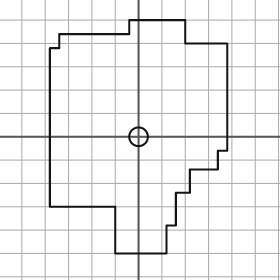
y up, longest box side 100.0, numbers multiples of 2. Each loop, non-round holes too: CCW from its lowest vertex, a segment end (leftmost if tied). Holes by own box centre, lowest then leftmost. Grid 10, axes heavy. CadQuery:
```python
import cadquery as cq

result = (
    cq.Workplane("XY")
    .moveTo(-10.0, -50.0)
    .lineTo(12.0, -50.0)
    .lineTo(12.0, -38.0)
    .lineTo(16.0, -38.0)
    .lineTo(16.0, -24.0)
    .lineTo(22.0, -24.0)
    .lineTo(22.0, -14.0)
    .lineTo(34.0, -14.0)
    .lineTo(34.0, -6.0)
    .lineTo(38.0, -6.0)
    .lineTo(38.0, 40.0)
    .lineTo(20.0, 40.0)
    .lineTo(20.0, 50.0)
    .lineTo(-4.0, 50.0)
    .lineTo(-4.0, 44.0)
    .lineTo(-34.0, 44.0)
    .lineTo(-34.0, 38.0)
    .lineTo(-38.0, 38.0)
    .lineTo(-38.0, -30.0)
    .lineTo(-10.0, -30.0)
    .close()
    .moveTo(0.0, 0.0)
    .circle(4.0)
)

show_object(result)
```